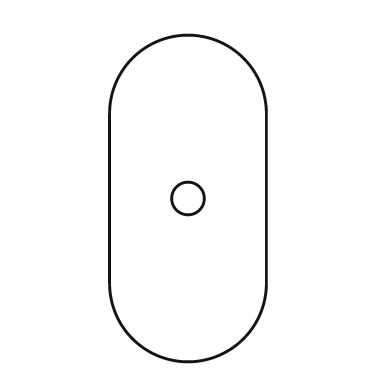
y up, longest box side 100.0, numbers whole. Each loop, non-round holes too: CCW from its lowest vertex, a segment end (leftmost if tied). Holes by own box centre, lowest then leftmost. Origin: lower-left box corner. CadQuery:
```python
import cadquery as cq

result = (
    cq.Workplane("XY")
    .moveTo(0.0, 24.0)
    .threePointArc((24.0, 0.0), (48.0, 24.0))
    .lineTo(48.0, 76.0)
    .threePointArc((24.0, 100.0), (0.0, 76.0))
    .close()
    .moveTo(24.0, 50.0)
    .circle(5.0)
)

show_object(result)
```